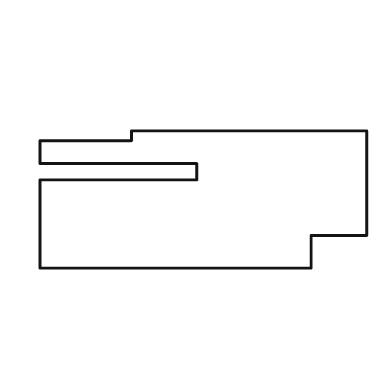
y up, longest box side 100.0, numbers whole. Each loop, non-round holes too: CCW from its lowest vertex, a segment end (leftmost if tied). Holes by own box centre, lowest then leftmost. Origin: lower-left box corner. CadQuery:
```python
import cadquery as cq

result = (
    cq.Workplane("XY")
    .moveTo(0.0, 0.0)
    .lineTo(83.0, 0.0)
    .lineTo(83.0, 10.0)
    .lineTo(100.0, 10.0)
    .lineTo(100.0, 42.0)
    .lineTo(28.0, 42.0)
    .lineTo(28.0, 39.0)
    .lineTo(0.0, 39.0)
    .lineTo(0.0, 32.0)
    .lineTo(48.0, 32.0)
    .lineTo(48.0, 27.0)
    .lineTo(0.0, 27.0)
    .close()
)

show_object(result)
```